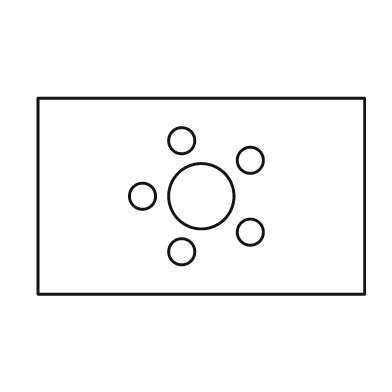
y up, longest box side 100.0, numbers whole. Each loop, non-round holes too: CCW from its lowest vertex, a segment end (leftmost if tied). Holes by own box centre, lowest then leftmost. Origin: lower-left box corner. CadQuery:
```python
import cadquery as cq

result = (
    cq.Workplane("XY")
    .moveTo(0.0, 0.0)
    .lineTo(100.0, 0.0)
    .lineTo(100.0, 60.0)
    .lineTo(0.0, 60.0)
    .close()
    .moveTo(44.0, 13.0)
    .circle(4.0)
    .moveTo(65.0, 19.0)
    .circle(4.0)
    .moveTo(32.0, 30.0)
    .circle(4.0)
    .moveTo(50.0, 30.0)
    .circle(10.0)
    .moveTo(65.0, 41.0)
    .circle(4.0)
    .moveTo(44.0, 47.0)
    .circle(4.0)
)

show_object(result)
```